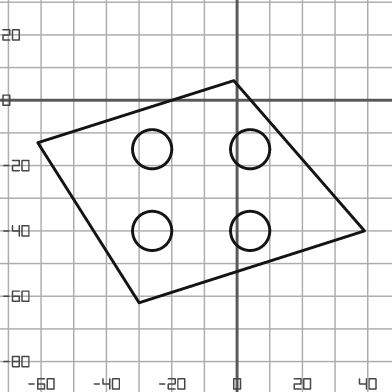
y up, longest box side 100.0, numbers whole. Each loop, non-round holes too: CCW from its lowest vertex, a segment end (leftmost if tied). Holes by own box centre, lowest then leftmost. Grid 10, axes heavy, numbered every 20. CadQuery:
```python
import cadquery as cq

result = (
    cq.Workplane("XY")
    .moveTo(-30.0, -62.0)
    .lineTo(39.0, -40.0)
    .lineTo(-1.0, 6.0)
    .lineTo(-61.0, -13.0)
    .close()
    .moveTo(-26.0, -40.0)
    .circle(6.0)
    .moveTo(4.0, -40.0)
    .circle(6.0)
    .moveTo(-26.0, -15.0)
    .circle(6.0)
    .moveTo(4.0, -15.0)
    .circle(6.0)
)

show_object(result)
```